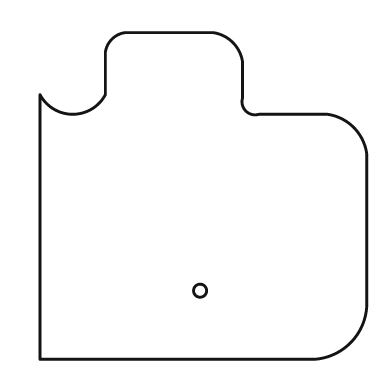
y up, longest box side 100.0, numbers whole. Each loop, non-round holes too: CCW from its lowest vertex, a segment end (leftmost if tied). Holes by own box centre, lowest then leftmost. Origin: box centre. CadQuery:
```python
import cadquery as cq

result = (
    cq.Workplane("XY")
    .moveTo(-50.0, -50.0)
    .lineTo(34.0, -50.0)
    .threePointArc((45.0, -45.0), (50.0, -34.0))
    .lineTo(50.0, 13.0)
    .threePointArc((46.0, 21.0), (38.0, 25.0))
    .lineTo(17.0, 25.0)
    .threePointArc((13.0, 26.0), (12.0, 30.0))
    .lineTo(12.0, 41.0)
    .threePointArc((9.0, 47.0), (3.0, 50.0))
    .lineTo(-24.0, 50.0)
    .threePointArc((-28.0, 48.0), (-30.0, 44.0))
    .lineTo(-30.0, 31.0)
    .threePointArc((-40.0, 25.0), (-50.0, 31.0))
    .close()
    .moveTo(-1.0, -29.0)
    .circle(2.0)
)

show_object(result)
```